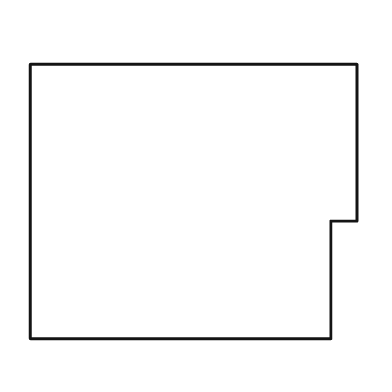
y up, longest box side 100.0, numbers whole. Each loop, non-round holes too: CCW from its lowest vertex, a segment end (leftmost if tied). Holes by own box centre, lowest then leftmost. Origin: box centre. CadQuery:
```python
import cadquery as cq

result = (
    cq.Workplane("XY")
    .moveTo(-50.0, -42.0)
    .lineTo(42.0, -42.0)
    .lineTo(42.0, -6.0)
    .lineTo(50.0, -6.0)
    .lineTo(50.0, 42.0)
    .lineTo(-50.0, 42.0)
    .close()
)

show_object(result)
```